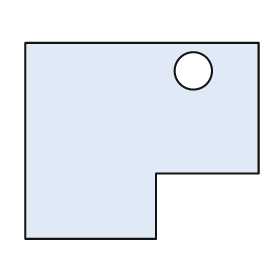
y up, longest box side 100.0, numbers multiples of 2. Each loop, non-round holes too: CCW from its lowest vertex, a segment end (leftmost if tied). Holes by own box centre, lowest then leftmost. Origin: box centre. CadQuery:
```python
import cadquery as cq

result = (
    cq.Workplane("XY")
    .moveTo(-50.0, -42.0)
    .lineTo(6.0, -42.0)
    .lineTo(6.0, -14.0)
    .lineTo(50.0, -14.0)
    .lineTo(50.0, 42.0)
    .lineTo(-50.0, 42.0)
    .close()
    .moveTo(22.0, 30.0)
    .circle(8.0)
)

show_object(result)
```